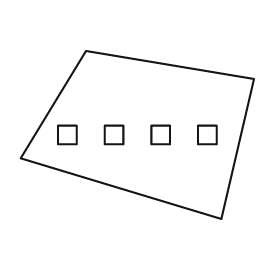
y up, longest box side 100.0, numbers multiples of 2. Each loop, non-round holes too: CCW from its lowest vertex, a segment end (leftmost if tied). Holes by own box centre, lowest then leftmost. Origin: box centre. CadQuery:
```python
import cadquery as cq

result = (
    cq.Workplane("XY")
    .moveTo(36.0, -36.0)
    .lineTo(50.0, 24.0)
    .lineTo(-22.0, 36.0)
    .lineTo(-50.0, -10.0)
    .close()
    .moveTo(-34.0, -4.0)
    .lineTo(-26.0, -4.0)
    .lineTo(-26.0, 4.0)
    .lineTo(-34.0, 4.0)
    .close()
    .moveTo(-14.0, -4.0)
    .lineTo(-6.0, -4.0)
    .lineTo(-6.0, 4.0)
    .lineTo(-14.0, 4.0)
    .close()
    .moveTo(6.0, -4.0)
    .lineTo(14.0, -4.0)
    .lineTo(14.0, 4.0)
    .lineTo(6.0, 4.0)
    .close()
    .moveTo(26.0, -4.0)
    .lineTo(34.0, -4.0)
    .lineTo(34.0, 4.0)
    .lineTo(26.0, 4.0)
    .close()
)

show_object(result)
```